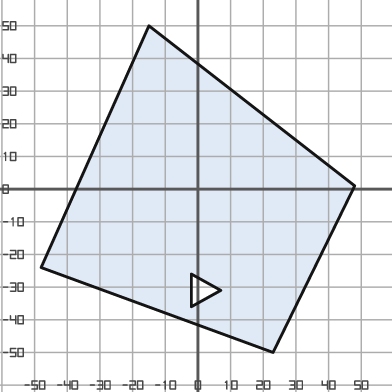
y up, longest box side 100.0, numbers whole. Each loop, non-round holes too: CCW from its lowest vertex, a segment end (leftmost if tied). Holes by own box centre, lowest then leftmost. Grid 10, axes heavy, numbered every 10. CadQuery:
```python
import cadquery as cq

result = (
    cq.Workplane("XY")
    .moveTo(23.0, -50.0)
    .lineTo(48.0, 1.0)
    .lineTo(-15.0, 50.0)
    .lineTo(-48.0, -24.0)
    .close()
    .moveTo(-2.0, -36.0)
    .lineTo(7.0, -31.0)
    .lineTo(-2.0, -26.0)
    .close()
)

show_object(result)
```